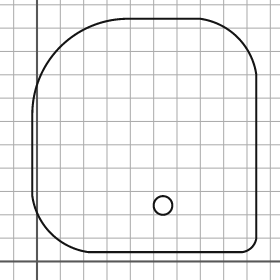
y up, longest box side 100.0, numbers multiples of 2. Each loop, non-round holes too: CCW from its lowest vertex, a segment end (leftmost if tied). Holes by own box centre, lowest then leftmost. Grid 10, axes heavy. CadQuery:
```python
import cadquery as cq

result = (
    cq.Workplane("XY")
    .moveTo(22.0, 4.0)
    .lineTo(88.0, 4.0)
    .threePointArc((92.0, 6.0), (94.0, 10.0))
    .lineTo(94.0, 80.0)
    .threePointArc((86.0, 96.0), (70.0, 104.0))
    .lineTo(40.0, 104.0)
    .threePointArc((10.0, 92.0), (-2.0, 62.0))
    .lineTo(-2.0, 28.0)
    .threePointArc((6.0, 12.0), (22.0, 4.0))
    .close()
    .moveTo(54.0, 24.0)
    .circle(4.0)
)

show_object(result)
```